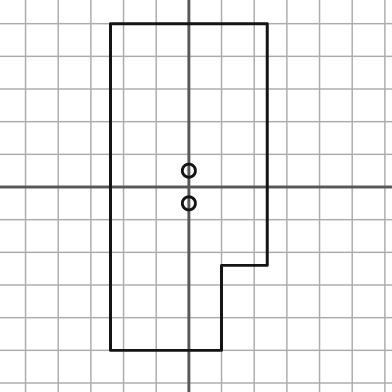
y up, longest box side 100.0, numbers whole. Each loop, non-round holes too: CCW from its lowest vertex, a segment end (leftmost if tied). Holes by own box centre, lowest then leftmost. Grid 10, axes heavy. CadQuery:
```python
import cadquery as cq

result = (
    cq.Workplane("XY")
    .moveTo(-24.0, -50.0)
    .lineTo(10.0, -50.0)
    .lineTo(10.0, -24.0)
    .lineTo(24.0, -24.0)
    .lineTo(24.0, 50.0)
    .lineTo(-24.0, 50.0)
    .close()
    .moveTo(0.0, -5.0)
    .circle(2.0)
    .moveTo(0.0, 5.0)
    .circle(2.0)
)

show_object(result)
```